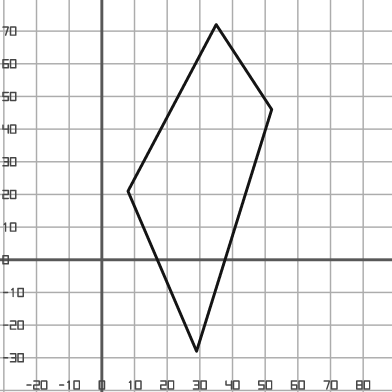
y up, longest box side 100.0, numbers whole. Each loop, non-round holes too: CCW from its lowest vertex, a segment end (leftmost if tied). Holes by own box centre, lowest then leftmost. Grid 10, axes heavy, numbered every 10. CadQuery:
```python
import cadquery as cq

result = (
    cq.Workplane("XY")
    .moveTo(29.0, -28.0)
    .lineTo(52.0, 46.0)
    .lineTo(35.0, 72.0)
    .lineTo(8.0, 21.0)
    .close()
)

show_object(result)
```